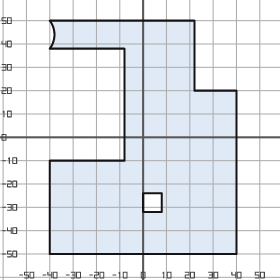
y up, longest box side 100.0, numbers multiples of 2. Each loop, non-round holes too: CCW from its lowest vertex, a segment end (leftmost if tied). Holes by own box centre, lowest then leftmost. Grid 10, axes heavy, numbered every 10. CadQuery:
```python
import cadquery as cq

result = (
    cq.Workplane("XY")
    .moveTo(-40.0, -50.0)
    .lineTo(40.0, -50.0)
    .lineTo(40.0, 20.0)
    .lineTo(22.0, 20.0)
    .lineTo(22.0, 50.0)
    .lineTo(-40.0, 50.0)
    .threePointArc((-38.0, 44.0), (-40.0, 38.0))
    .lineTo(-8.0, 38.0)
    .lineTo(-8.0, -10.0)
    .lineTo(-40.0, -10.0)
    .close()
    .moveTo(0.0, -32.0)
    .lineTo(8.0, -32.0)
    .lineTo(8.0, -24.0)
    .lineTo(0.0, -24.0)
    .close()
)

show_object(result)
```